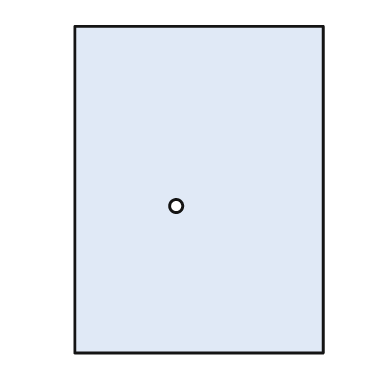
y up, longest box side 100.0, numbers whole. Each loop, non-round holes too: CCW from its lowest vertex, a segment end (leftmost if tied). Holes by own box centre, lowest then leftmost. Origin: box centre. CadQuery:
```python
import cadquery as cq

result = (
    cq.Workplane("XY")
    .moveTo(-38.0, -50.0)
    .lineTo(38.0, -50.0)
    .lineTo(38.0, 50.0)
    .lineTo(-38.0, 50.0)
    .close()
    .moveTo(-7.0, -5.0)
    .circle(2.0)
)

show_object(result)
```